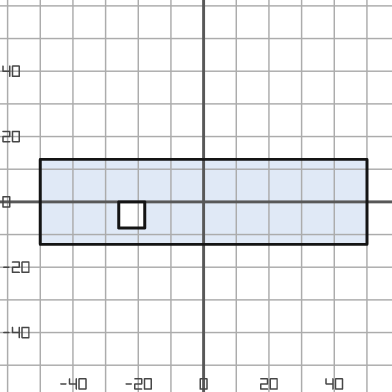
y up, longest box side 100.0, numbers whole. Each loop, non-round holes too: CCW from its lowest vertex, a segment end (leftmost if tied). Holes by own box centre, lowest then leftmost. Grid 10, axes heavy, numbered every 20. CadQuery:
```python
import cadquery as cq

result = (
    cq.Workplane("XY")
    .moveTo(-50.0, -13.0)
    .lineTo(50.0, -13.0)
    .lineTo(50.0, 13.0)
    .lineTo(-50.0, 13.0)
    .close()
    .moveTo(-26.0, -8.0)
    .lineTo(-18.0, -8.0)
    .lineTo(-18.0, 0.0)
    .lineTo(-26.0, 0.0)
    .close()
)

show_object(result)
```